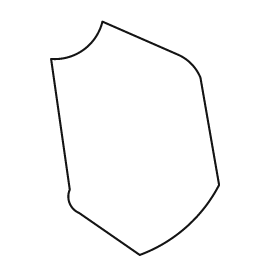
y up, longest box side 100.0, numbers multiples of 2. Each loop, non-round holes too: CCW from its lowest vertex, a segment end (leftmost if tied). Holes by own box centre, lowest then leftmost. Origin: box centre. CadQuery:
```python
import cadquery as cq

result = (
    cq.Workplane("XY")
    .moveTo(2.0, -50.0)
    .threePointArc((22.0, -38.0), (36.0, -20.0))
    .lineTo(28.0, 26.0)
    .threePointArc((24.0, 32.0), (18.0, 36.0))
    .lineTo(-14.0, 50.0)
    .threePointArc((-22.0, 38.0), (-36.0, 34.0))
    .lineTo(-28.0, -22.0)
    .threePointArc((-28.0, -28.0), (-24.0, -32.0))
    .close()
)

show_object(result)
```